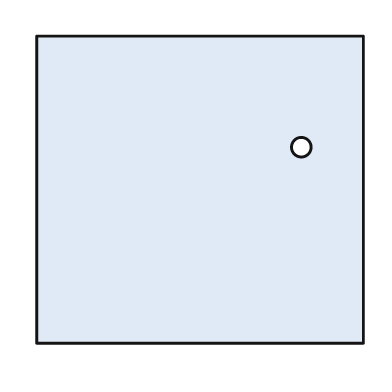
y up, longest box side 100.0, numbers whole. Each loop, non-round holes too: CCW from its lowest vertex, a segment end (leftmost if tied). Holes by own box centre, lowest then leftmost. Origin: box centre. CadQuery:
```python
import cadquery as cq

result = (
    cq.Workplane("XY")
    .moveTo(-50.0, -47.0)
    .lineTo(50.0, -47.0)
    .lineTo(50.0, 47.0)
    .lineTo(-50.0, 47.0)
    .close()
    .moveTo(31.0, 13.0)
    .circle(3.0)
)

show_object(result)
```